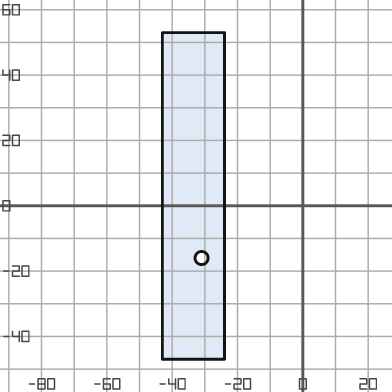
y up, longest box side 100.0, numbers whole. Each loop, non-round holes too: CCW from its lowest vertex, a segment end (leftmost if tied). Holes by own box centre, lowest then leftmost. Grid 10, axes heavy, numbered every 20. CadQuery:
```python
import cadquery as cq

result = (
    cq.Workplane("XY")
    .moveTo(-43.0, -47.0)
    .lineTo(-24.0, -47.0)
    .lineTo(-24.0, 53.0)
    .lineTo(-43.0, 53.0)
    .close()
    .moveTo(-31.0, -16.0)
    .circle(2.0)
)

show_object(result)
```